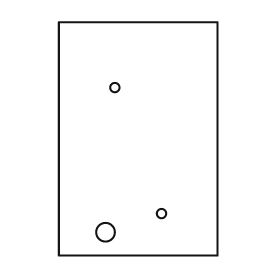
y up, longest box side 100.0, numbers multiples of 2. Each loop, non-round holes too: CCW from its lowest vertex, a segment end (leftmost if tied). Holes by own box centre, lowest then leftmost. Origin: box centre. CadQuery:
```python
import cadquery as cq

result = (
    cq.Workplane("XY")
    .moveTo(-34.0, -50.0)
    .lineTo(34.0, -50.0)
    .lineTo(34.0, 50.0)
    .lineTo(-34.0, 50.0)
    .close()
    .moveTo(-14.0, -40.0)
    .circle(4.0)
    .moveTo(10.0, -32.0)
    .circle(2.0)
    .moveTo(-10.0, 22.0)
    .circle(2.0)
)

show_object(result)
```